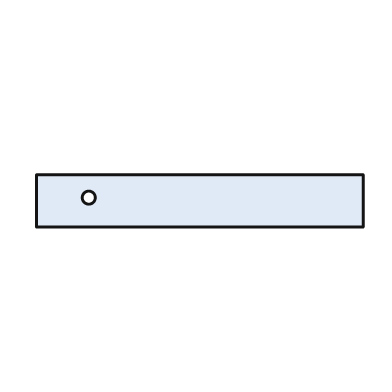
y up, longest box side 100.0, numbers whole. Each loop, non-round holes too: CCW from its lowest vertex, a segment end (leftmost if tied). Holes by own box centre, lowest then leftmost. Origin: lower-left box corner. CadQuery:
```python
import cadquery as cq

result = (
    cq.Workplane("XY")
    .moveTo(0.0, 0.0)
    .lineTo(100.0, 0.0)
    .lineTo(100.0, 16.0)
    .lineTo(0.0, 16.0)
    .close()
    .moveTo(16.0, 9.0)
    .circle(2.0)
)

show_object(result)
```